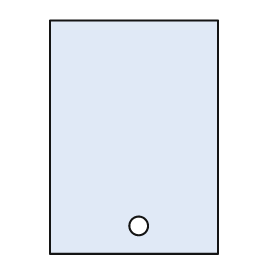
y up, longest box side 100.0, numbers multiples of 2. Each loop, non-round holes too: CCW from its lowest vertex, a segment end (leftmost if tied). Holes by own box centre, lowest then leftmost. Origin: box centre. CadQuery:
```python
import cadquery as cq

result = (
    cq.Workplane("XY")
    .moveTo(-36.0, -50.0)
    .lineTo(36.0, -50.0)
    .lineTo(36.0, 50.0)
    .lineTo(-36.0, 50.0)
    .close()
    .moveTo(2.0, -38.0)
    .circle(4.0)
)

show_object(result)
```